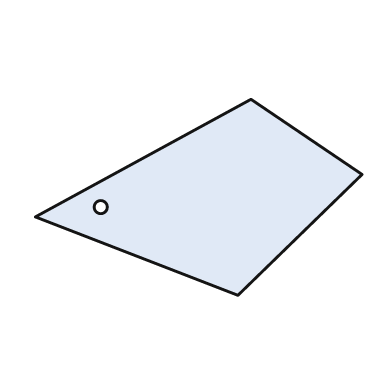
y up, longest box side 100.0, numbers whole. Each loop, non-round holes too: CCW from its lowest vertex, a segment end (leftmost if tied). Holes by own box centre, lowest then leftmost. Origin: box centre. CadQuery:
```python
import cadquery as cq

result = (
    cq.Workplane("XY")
    .moveTo(12.0, -30.0)
    .lineTo(50.0, 7.0)
    .lineTo(16.0, 30.0)
    .lineTo(-50.0, -6.0)
    .close()
    .moveTo(-30.0, -3.0)
    .circle(2.0)
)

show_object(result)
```